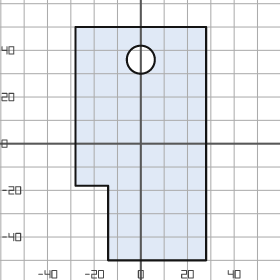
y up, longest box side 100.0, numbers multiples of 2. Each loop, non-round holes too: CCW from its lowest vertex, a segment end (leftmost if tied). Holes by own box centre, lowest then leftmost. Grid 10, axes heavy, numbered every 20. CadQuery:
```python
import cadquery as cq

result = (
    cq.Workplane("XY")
    .moveTo(-14.0, -50.0)
    .lineTo(28.0, -50.0)
    .lineTo(28.0, 50.0)
    .lineTo(-28.0, 50.0)
    .lineTo(-28.0, -18.0)
    .lineTo(-14.0, -18.0)
    .close()
    .moveTo(0.0, 36.0)
    .circle(6.0)
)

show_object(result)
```